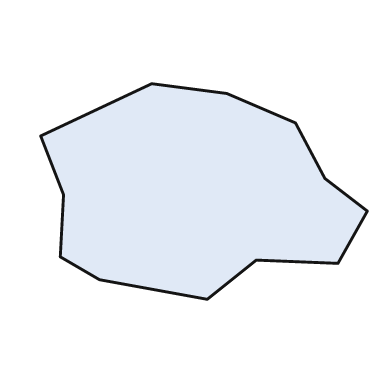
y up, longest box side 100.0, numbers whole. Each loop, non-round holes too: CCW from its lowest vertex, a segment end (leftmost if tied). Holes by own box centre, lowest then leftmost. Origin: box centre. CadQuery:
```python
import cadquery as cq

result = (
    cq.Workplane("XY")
    .moveTo(1.0, -33.0)
    .lineTo(16.0, -21.0)
    .lineTo(41.0, -22.0)
    .lineTo(50.0, -6.0)
    .lineTo(37.0, 4.0)
    .lineTo(28.0, 21.0)
    .lineTo(7.0, 30.0)
    .lineTo(-16.0, 33.0)
    .lineTo(-50.0, 17.0)
    .lineTo(-43.0, -1.0)
    .lineTo(-44.0, -20.0)
    .lineTo(-32.0, -27.0)
    .close()
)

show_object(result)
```